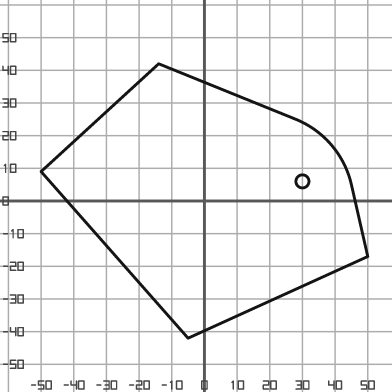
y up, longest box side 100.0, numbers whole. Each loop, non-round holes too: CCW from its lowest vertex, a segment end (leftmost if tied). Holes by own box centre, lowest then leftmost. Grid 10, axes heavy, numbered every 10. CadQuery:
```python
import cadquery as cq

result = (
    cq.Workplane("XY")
    .moveTo(-5.0, -42.0)
    .lineTo(50.0, -17.0)
    .lineTo(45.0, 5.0)
    .threePointArc((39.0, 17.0), (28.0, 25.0))
    .lineTo(-14.0, 42.0)
    .lineTo(-50.0, 9.0)
    .close()
    .moveTo(30.0, 6.0)
    .circle(2.0)
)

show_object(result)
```